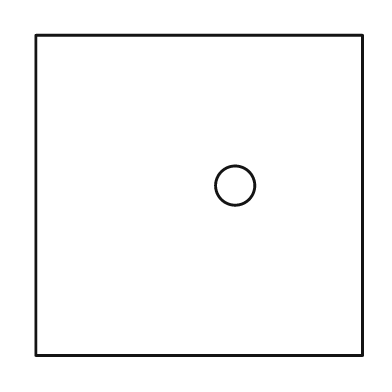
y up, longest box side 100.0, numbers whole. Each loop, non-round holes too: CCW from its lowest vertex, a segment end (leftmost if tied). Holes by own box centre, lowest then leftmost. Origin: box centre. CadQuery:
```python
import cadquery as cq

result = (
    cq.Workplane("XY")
    .moveTo(-50.0, -49.0)
    .lineTo(50.0, -49.0)
    .lineTo(50.0, 49.0)
    .lineTo(-50.0, 49.0)
    .close()
    .moveTo(11.0, 3.0)
    .circle(6.0)
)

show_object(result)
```